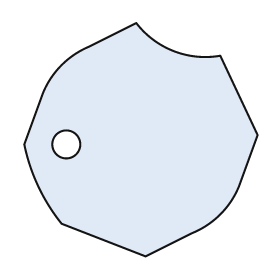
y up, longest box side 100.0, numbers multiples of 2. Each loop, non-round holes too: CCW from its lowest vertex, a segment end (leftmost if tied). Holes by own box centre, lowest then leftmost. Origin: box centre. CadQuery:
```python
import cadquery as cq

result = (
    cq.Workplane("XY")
    .moveTo(2.0, -50.0)
    .lineTo(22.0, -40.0)
    .threePointArc((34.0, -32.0), (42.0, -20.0))
    .lineTo(50.0, 2.0)
    .lineTo(34.0, 36.0)
    .threePointArc((14.0, 38.0), (-2.0, 50.0))
    .lineTo(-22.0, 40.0)
    .threePointArc((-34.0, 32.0), (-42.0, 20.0))
    .lineTo(-50.0, -2.0)
    .threePointArc((-44.0, -20.0), (-34.0, -36.0))
    .close()
    .moveTo(-32.0, -2.0)
    .circle(6.0)
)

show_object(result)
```